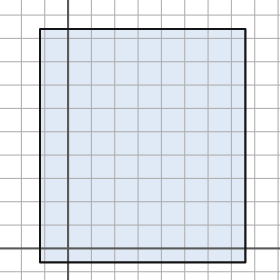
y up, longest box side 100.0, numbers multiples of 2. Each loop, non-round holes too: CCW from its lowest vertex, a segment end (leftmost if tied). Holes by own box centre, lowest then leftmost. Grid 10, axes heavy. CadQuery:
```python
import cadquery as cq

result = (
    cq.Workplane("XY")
    .moveTo(-12.0, -6.0)
    .lineTo(76.0, -6.0)
    .lineTo(76.0, 94.0)
    .lineTo(-12.0, 94.0)
    .close()
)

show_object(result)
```